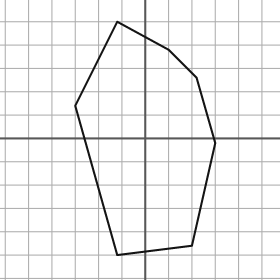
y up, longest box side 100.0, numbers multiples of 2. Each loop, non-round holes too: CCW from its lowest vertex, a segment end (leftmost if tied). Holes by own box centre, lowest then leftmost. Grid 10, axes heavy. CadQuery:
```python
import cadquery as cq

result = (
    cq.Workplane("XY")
    .moveTo(-12.0, -50.0)
    .lineTo(20.0, -46.0)
    .lineTo(30.0, -2.0)
    .lineTo(22.0, 26.0)
    .lineTo(10.0, 38.0)
    .lineTo(-12.0, 50.0)
    .lineTo(-30.0, 14.0)
    .close()
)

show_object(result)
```